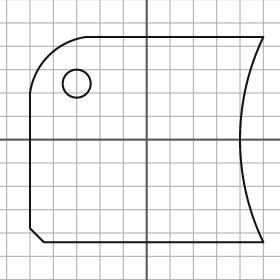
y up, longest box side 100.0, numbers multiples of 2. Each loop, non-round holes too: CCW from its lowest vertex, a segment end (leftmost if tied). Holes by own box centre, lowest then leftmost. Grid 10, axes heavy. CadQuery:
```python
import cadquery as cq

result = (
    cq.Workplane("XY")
    .moveTo(-44.0, -44.0)
    .lineTo(50.0, -44.0)
    .threePointArc((40.0, 0.0), (50.0, 44.0))
    .lineTo(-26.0, 44.0)
    .threePointArc((-42.0, 36.0), (-50.0, 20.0))
    .lineTo(-50.0, -38.0)
    .close()
    .moveTo(-30.0, 24.0)
    .circle(6.0)
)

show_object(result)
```